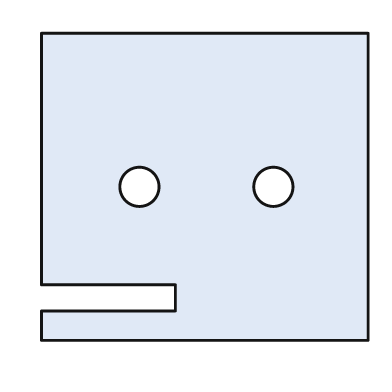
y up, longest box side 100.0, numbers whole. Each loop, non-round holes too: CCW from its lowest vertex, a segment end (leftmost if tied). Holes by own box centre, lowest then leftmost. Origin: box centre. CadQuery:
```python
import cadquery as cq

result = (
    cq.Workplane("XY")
    .moveTo(-50.0, -47.0)
    .lineTo(50.0, -47.0)
    .lineTo(50.0, 47.0)
    .lineTo(-50.0, 47.0)
    .lineTo(-50.0, -30.0)
    .lineTo(-9.0, -30.0)
    .lineTo(-9.0, -38.0)
    .lineTo(-50.0, -38.0)
    .close()
    .moveTo(-20.0, 0.0)
    .circle(6.0)
    .moveTo(21.0, 0.0)
    .circle(6.0)
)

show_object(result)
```